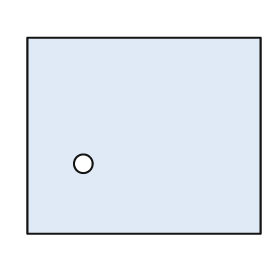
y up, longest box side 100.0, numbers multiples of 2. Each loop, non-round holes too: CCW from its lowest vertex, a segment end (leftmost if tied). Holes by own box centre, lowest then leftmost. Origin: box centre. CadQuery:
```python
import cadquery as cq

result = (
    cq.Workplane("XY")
    .moveTo(-50.0, -42.0)
    .lineTo(50.0, -42.0)
    .lineTo(50.0, 42.0)
    .lineTo(-50.0, 42.0)
    .close()
    .moveTo(-26.0, -12.0)
    .circle(4.0)
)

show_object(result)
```